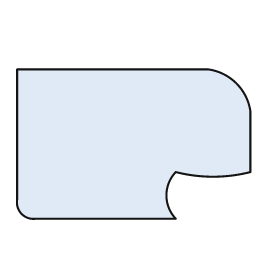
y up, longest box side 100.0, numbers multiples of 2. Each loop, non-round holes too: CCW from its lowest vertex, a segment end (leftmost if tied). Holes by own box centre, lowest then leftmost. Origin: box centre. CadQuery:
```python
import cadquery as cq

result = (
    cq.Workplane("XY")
    .moveTo(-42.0, -32.0)
    .lineTo(18.0, -32.0)
    .threePointArc((14.0, -22.0), (18.0, -12.0))
    .threePointArc((34.0, -14.0), (50.0, -12.0))
    .lineTo(50.0, 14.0)
    .threePointArc((44.0, 26.0), (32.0, 32.0))
    .lineTo(-50.0, 32.0)
    .lineTo(-50.0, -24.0)
    .threePointArc((-48.0, -30.0), (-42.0, -32.0))
    .close()
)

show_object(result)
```